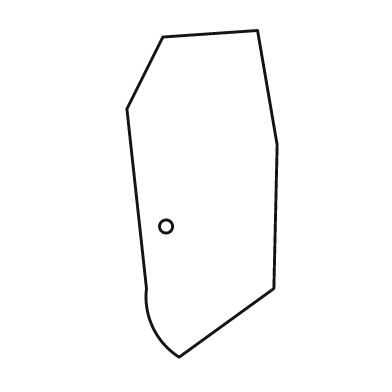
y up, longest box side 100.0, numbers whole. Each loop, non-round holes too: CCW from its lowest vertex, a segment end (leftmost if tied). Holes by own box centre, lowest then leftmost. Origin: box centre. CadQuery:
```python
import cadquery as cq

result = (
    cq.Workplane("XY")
    .moveTo(-7.0, -50.0)
    .lineTo(22.0, -29.0)
    .lineTo(23.0, 15.0)
    .lineTo(17.0, 50.0)
    .lineTo(-12.0, 48.0)
    .lineTo(-23.0, 26.0)
    .lineTo(-17.0, -29.0)
    .threePointArc((-15.0, -41.0), (-7.0, -50.0))
    .close()
    .moveTo(-11.0, -10.0)
    .circle(2.0)
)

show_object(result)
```